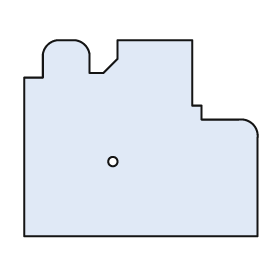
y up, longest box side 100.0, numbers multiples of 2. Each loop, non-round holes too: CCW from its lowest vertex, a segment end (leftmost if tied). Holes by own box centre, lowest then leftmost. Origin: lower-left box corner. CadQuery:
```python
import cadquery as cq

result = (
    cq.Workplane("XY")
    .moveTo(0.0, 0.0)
    .lineTo(100.0, 0.0)
    .lineTo(100.0, 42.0)
    .threePointArc((98.0, 48.0), (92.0, 50.0))
    .lineTo(76.0, 50.0)
    .lineTo(76.0, 56.0)
    .lineTo(72.0, 56.0)
    .lineTo(72.0, 84.0)
    .lineTo(40.0, 84.0)
    .lineTo(40.0, 76.0)
    .lineTo(34.0, 70.0)
    .lineTo(28.0, 70.0)
    .lineTo(28.0, 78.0)
    .threePointArc((26.0, 82.0), (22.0, 84.0))
    .lineTo(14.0, 84.0)
    .threePointArc((10.0, 82.0), (8.0, 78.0))
    .lineTo(8.0, 68.0)
    .lineTo(0.0, 68.0)
    .close()
    .moveTo(38.0, 32.0)
    .circle(2.0)
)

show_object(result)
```